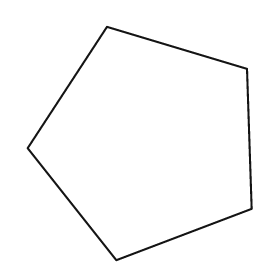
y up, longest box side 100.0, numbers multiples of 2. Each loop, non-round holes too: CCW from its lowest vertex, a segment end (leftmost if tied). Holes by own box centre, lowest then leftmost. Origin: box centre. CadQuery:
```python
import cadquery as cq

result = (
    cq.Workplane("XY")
    .moveTo(-10.0, -50.0)
    .lineTo(48.0, -28.0)
    .lineTo(46.0, 32.0)
    .lineTo(-14.0, 50.0)
    .lineTo(-48.0, -2.0)
    .close()
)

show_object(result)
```